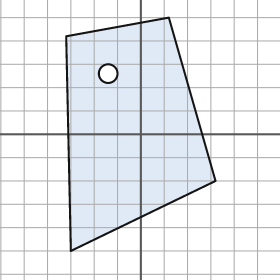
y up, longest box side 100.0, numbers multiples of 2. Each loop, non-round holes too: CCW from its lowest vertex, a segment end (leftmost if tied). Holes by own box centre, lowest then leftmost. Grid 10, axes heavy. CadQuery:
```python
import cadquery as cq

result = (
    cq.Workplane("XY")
    .moveTo(-30.0, -50.0)
    .lineTo(32.0, -20.0)
    .lineTo(12.0, 50.0)
    .lineTo(-32.0, 42.0)
    .close()
    .moveTo(-14.0, 26.0)
    .circle(4.0)
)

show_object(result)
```